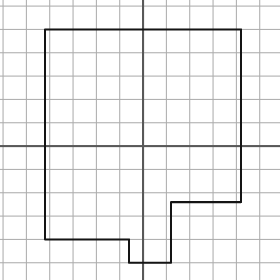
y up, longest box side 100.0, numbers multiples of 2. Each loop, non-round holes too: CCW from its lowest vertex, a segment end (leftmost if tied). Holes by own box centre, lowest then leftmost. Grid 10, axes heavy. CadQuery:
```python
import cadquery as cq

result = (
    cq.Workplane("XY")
    .moveTo(-6.0, -50.0)
    .lineTo(12.0, -50.0)
    .lineTo(12.0, -24.0)
    .lineTo(42.0, -24.0)
    .lineTo(42.0, 50.0)
    .lineTo(-42.0, 50.0)
    .lineTo(-42.0, -40.0)
    .lineTo(-6.0, -40.0)
    .close()
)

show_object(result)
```